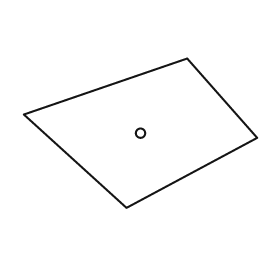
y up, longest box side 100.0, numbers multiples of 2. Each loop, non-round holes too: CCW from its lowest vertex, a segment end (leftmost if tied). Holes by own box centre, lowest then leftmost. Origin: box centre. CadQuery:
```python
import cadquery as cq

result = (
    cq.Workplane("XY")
    .moveTo(-6.0, -32.0)
    .lineTo(50.0, -2.0)
    .lineTo(20.0, 32.0)
    .lineTo(-50.0, 8.0)
    .close()
    .moveTo(0.0, 0.0)
    .circle(2.0)
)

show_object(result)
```